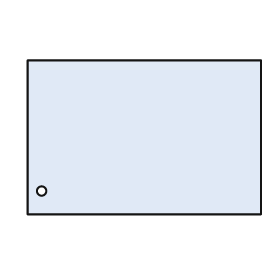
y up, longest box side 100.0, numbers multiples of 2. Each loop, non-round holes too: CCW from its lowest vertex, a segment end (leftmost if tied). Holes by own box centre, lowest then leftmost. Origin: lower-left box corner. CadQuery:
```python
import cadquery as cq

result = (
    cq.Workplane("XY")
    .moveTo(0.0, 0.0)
    .lineTo(100.0, 0.0)
    .lineTo(100.0, 66.0)
    .lineTo(0.0, 66.0)
    .close()
    .moveTo(6.0, 10.0)
    .circle(2.0)
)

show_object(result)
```